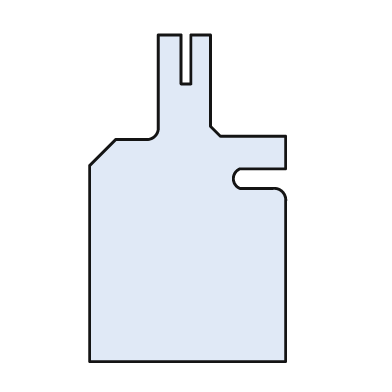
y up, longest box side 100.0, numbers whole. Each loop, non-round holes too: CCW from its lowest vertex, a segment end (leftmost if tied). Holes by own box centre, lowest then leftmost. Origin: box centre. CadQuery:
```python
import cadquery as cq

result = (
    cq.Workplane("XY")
    .moveTo(-30.0, -50.0)
    .lineTo(30.0, -50.0)
    .lineTo(30.0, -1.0)
    .threePointArc((29.0, 2.0), (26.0, 3.0))
    .lineTo(16.0, 3.0)
    .threePointArc((14.0, 6.0), (16.0, 9.0))
    .lineTo(30.0, 9.0)
    .lineTo(30.0, 19.0)
    .lineTo(10.0, 19.0)
    .lineTo(7.0, 22.0)
    .lineTo(7.0, 50.0)
    .lineTo(1.0, 50.0)
    .lineTo(1.0, 35.0)
    .lineTo(-2.0, 35.0)
    .lineTo(-2.0, 50.0)
    .lineTo(-9.0, 50.0)
    .lineTo(-9.0, 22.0)
    .threePointArc((-10.0, 19.0), (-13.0, 18.0))
    .lineTo(-22.0, 18.0)
    .lineTo(-30.0, 10.0)
    .close()
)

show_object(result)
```